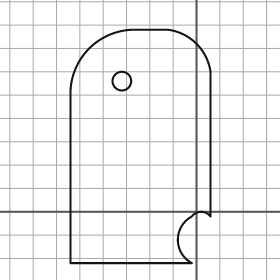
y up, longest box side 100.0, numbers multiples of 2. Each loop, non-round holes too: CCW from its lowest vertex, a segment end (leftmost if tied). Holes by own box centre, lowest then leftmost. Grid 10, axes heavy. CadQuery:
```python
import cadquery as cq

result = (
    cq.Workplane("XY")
    .moveTo(-54.0, -22.0)
    .lineTo(-2.0, -22.0)
    .threePointArc((-8.0, -12.0), (-2.0, -2.0))
    .threePointArc((2.0, 0.0), (6.0, -2.0))
    .lineTo(6.0, 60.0)
    .threePointArc((0.0, 72.0), (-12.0, 78.0))
    .lineTo(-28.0, 78.0)
    .threePointArc((-46.0, 70.0), (-54.0, 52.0))
    .close()
    .moveTo(-32.0, 56.0)
    .circle(4.0)
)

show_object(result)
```